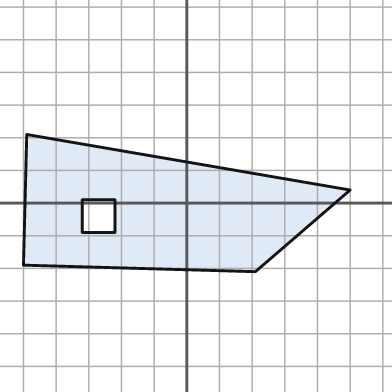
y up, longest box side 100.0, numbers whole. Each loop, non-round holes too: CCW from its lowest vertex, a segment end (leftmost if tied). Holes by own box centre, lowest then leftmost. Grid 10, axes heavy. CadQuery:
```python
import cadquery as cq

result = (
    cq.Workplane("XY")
    .moveTo(21.0, -21.0)
    .lineTo(50.0, 4.0)
    .lineTo(-49.0, 21.0)
    .lineTo(-50.0, -19.0)
    .close()
    .moveTo(-32.0, -9.0)
    .lineTo(-22.0, -9.0)
    .lineTo(-22.0, 1.0)
    .lineTo(-32.0, 1.0)
    .close()
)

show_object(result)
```